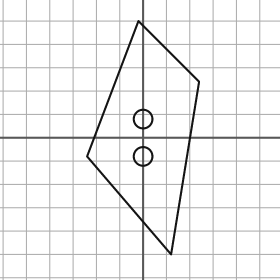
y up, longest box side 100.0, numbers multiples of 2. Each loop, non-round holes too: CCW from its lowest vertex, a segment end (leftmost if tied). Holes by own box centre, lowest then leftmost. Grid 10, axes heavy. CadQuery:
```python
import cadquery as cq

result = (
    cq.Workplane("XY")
    .moveTo(12.0, -50.0)
    .lineTo(24.0, 24.0)
    .lineTo(-2.0, 50.0)
    .lineTo(-24.0, -8.0)
    .close()
    .moveTo(0.0, -8.0)
    .circle(4.0)
    .moveTo(0.0, 8.0)
    .circle(4.0)
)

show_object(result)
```